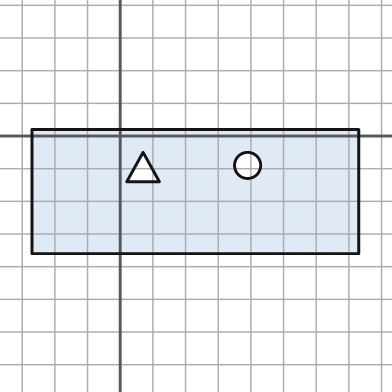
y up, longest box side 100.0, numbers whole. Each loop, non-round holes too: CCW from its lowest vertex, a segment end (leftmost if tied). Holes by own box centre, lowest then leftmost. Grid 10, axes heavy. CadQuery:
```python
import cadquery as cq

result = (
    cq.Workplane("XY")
    .moveTo(-27.0, -36.0)
    .lineTo(73.0, -36.0)
    .lineTo(73.0, 2.0)
    .lineTo(-27.0, 2.0)
    .close()
    .moveTo(2.0, -14.0)
    .lineTo(12.0, -14.0)
    .lineTo(7.0, -5.0)
    .close()
    .moveTo(39.0, -9.0)
    .circle(4.0)
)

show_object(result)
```